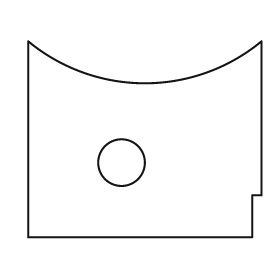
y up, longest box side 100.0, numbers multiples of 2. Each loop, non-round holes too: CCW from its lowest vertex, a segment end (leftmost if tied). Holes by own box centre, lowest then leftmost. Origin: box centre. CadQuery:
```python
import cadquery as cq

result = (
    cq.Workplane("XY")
    .moveTo(-50.0, -42.0)
    .lineTo(46.0, -42.0)
    .lineTo(46.0, -24.0)
    .lineTo(50.0, -24.0)
    .lineTo(50.0, 42.0)
    .threePointArc((0.0, 24.0), (-50.0, 42.0))
    .close()
    .moveTo(-10.0, -10.0)
    .circle(10.0)
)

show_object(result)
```